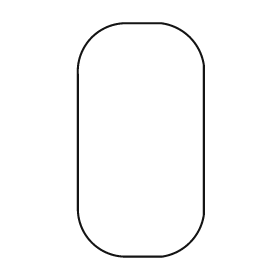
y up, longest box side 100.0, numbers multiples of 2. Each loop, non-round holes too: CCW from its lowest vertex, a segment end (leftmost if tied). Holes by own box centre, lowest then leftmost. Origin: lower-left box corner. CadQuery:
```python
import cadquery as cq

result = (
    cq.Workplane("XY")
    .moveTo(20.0, 0.0)
    .lineTo(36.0, 0.0)
    .threePointArc((48.0, 6.0), (54.0, 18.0))
    .lineTo(54.0, 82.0)
    .threePointArc((48.0, 94.0), (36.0, 100.0))
    .lineTo(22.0, 100.0)
    .threePointArc((6.0, 94.0), (0.0, 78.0))
    .lineTo(0.0, 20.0)
    .threePointArc((6.0, 6.0), (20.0, 0.0))
    .close()
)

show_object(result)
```